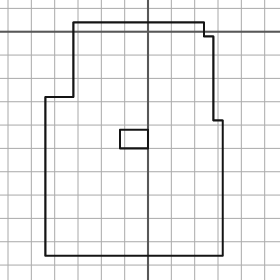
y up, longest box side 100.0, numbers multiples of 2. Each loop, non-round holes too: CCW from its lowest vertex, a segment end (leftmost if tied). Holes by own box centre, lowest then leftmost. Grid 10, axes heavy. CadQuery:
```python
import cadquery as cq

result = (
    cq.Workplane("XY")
    .moveTo(-44.0, -96.0)
    .lineTo(32.0, -96.0)
    .lineTo(32.0, -38.0)
    .lineTo(28.0, -38.0)
    .lineTo(28.0, -2.0)
    .lineTo(24.0, -2.0)
    .lineTo(24.0, 4.0)
    .lineTo(-32.0, 4.0)
    .lineTo(-32.0, -28.0)
    .lineTo(-44.0, -28.0)
    .close()
    .moveTo(-12.0, -50.0)
    .lineTo(0.0, -50.0)
    .lineTo(0.0, -42.0)
    .lineTo(-12.0, -42.0)
    .close()
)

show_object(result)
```